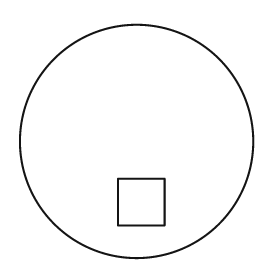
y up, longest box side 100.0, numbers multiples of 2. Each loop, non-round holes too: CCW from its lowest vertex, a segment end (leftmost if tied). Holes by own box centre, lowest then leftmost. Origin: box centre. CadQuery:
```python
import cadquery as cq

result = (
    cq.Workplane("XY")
    .moveTo(0.0, 0.0)
    .circle(50.0)
    .moveTo(-8.0, -36.0)
    .lineTo(12.0, -36.0)
    .lineTo(12.0, -16.0)
    .lineTo(-8.0, -16.0)
    .close()
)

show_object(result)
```